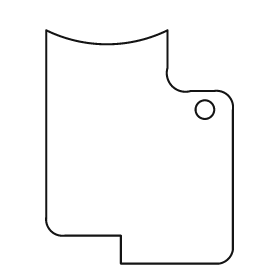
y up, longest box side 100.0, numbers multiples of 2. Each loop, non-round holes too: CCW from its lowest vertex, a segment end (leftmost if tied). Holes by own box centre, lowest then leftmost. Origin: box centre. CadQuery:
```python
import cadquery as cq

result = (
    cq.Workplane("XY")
    .moveTo(-8.0, -50.0)
    .lineTo(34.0, -50.0)
    .threePointArc((38.0, -48.0), (40.0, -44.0))
    .lineTo(40.0, 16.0)
    .threePointArc((38.0, 22.0), (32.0, 24.0))
    .lineTo(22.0, 24.0)
    .threePointArc((14.0, 26.0), (12.0, 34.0))
    .lineTo(12.0, 50.0)
    .threePointArc((-14.0, 44.0), (-40.0, 50.0))
    .lineTo(-40.0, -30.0)
    .threePointArc((-38.0, -36.0), (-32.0, -38.0))
    .lineTo(-8.0, -38.0)
    .close()
    .moveTo(28.0, 16.0)
    .circle(4.0)
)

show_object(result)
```